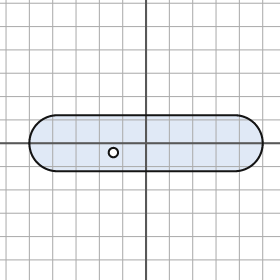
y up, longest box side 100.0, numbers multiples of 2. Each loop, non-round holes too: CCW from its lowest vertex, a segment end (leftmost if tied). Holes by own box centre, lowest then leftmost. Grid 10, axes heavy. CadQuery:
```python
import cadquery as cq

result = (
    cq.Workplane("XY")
    .moveTo(-38.0, -12.0)
    .lineTo(38.0, -12.0)
    .threePointArc((50.0, 0.0), (38.0, 12.0))
    .lineTo(-38.0, 12.0)
    .threePointArc((-50.0, 0.0), (-38.0, -12.0))
    .close()
    .moveTo(-14.0, -4.0)
    .circle(2.0)
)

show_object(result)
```